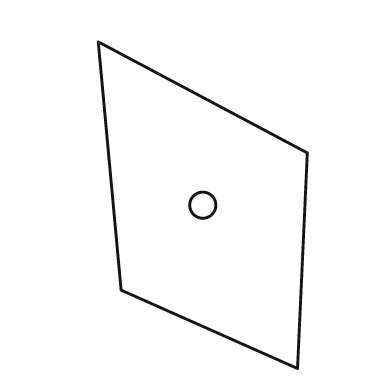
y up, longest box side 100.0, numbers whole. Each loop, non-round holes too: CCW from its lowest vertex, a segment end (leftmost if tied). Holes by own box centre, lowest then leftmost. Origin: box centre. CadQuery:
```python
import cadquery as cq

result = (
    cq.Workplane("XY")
    .moveTo(29.0, -50.0)
    .lineTo(32.0, 16.0)
    .lineTo(-32.0, 50.0)
    .lineTo(-25.0, -26.0)
    .close()
    .moveTo(0.0, 0.0)
    .circle(4.0)
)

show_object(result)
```